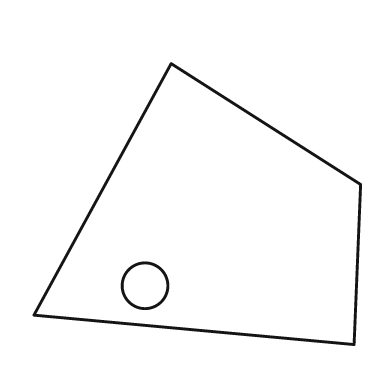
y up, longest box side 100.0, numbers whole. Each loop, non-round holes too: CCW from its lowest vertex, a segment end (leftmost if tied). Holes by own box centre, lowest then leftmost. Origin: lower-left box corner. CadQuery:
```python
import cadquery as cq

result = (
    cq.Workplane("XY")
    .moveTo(98.0, 0.0)
    .lineTo(100.0, 49.0)
    .lineTo(42.0, 86.0)
    .lineTo(0.0, 9.0)
    .close()
    .moveTo(34.0, 18.0)
    .circle(7.0)
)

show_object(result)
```